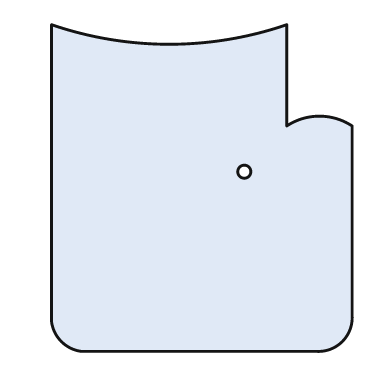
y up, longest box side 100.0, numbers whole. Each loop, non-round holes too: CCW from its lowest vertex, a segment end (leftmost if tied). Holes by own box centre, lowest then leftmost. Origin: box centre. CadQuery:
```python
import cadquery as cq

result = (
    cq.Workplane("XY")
    .moveTo(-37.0, -50.0)
    .lineTo(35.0, -50.0)
    .threePointArc((43.0, -47.0), (46.0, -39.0))
    .lineTo(46.0, 19.0)
    .threePointArc((36.0, 22.0), (26.0, 19.0))
    .lineTo(26.0, 50.0)
    .threePointArc((-10.0, 44.0), (-46.0, 50.0))
    .lineTo(-46.0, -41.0)
    .threePointArc((-43.0, -47.0), (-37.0, -50.0))
    .close()
    .moveTo(13.0, 5.0)
    .circle(2.0)
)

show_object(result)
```